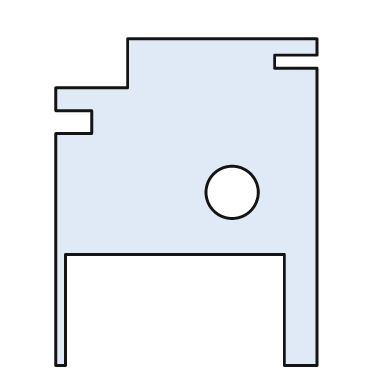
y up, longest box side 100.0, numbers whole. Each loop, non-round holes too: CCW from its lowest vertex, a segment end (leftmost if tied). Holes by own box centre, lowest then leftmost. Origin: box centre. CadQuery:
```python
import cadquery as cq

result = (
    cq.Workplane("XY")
    .moveTo(-40.0, -50.0)
    .lineTo(-37.0, -50.0)
    .lineTo(-37.0, -16.0)
    .lineTo(30.0, -16.0)
    .lineTo(30.0, -50.0)
    .lineTo(40.0, -50.0)
    .lineTo(40.0, 41.0)
    .lineTo(27.0, 41.0)
    .lineTo(27.0, 45.0)
    .lineTo(40.0, 45.0)
    .lineTo(40.0, 50.0)
    .lineTo(-18.0, 50.0)
    .lineTo(-18.0, 35.0)
    .lineTo(-40.0, 35.0)
    .lineTo(-40.0, 28.0)
    .lineTo(-29.0, 28.0)
    .lineTo(-29.0, 21.0)
    .lineTo(-40.0, 21.0)
    .close()
    .moveTo(14.0, 3.0)
    .circle(8.0)
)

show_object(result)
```